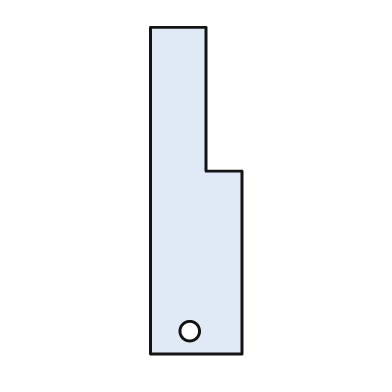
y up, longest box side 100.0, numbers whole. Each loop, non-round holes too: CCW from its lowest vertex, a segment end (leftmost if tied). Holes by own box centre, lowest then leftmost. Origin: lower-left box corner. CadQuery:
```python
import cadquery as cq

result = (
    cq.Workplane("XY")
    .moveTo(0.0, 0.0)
    .lineTo(28.0, 0.0)
    .lineTo(28.0, 56.0)
    .lineTo(17.0, 56.0)
    .lineTo(17.0, 100.0)
    .lineTo(0.0, 100.0)
    .close()
    .moveTo(12.0, 7.0)
    .circle(3.0)
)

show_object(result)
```